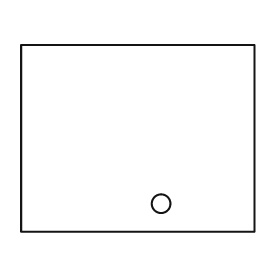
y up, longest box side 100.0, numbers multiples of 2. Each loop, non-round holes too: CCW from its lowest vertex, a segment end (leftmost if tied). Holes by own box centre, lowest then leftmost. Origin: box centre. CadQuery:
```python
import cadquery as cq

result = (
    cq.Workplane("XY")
    .moveTo(-50.0, -40.0)
    .lineTo(50.0, -40.0)
    .lineTo(50.0, 40.0)
    .lineTo(-50.0, 40.0)
    .close()
    .moveTo(10.0, -28.0)
    .circle(4.0)
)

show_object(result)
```